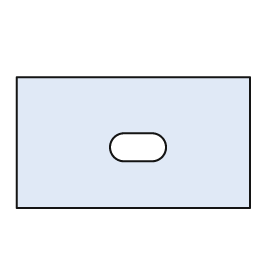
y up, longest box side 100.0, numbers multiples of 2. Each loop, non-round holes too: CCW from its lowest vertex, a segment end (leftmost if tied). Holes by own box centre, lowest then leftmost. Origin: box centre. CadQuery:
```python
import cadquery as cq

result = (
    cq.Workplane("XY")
    .moveTo(-50.0, -28.0)
    .lineTo(50.0, -28.0)
    .lineTo(50.0, 28.0)
    .lineTo(-50.0, 28.0)
    .close()
    .moveTo(-4.0, -8.0)
    .lineTo(8.0, -8.0)
    .threePointArc((14.0, -2.0), (8.0, 4.0))
    .lineTo(-4.0, 4.0)
    .threePointArc((-10.0, -2.0), (-4.0, -8.0))
    .close()
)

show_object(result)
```